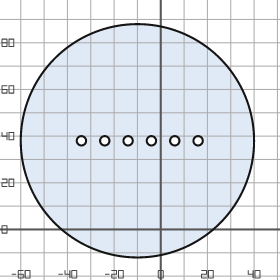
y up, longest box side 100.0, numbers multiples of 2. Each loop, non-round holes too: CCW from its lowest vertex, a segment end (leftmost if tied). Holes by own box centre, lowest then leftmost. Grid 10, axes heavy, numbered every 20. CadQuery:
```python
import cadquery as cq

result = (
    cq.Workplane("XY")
    .moveTo(-10.0, 38.0)
    .circle(50.0)
    .moveTo(-34.0, 38.0)
    .circle(2.0)
    .moveTo(-24.0, 38.0)
    .circle(2.0)
    .moveTo(-14.0, 38.0)
    .circle(2.0)
    .moveTo(-4.0, 38.0)
    .circle(2.0)
    .moveTo(6.0, 38.0)
    .circle(2.0)
    .moveTo(16.0, 38.0)
    .circle(2.0)
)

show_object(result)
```